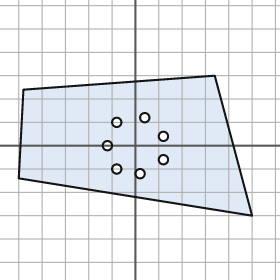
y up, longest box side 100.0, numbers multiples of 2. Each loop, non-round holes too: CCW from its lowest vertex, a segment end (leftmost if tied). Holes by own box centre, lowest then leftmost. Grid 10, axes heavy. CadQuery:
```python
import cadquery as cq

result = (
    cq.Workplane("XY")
    .moveTo(50.0, -30.0)
    .lineTo(34.0, 30.0)
    .lineTo(-48.0, 24.0)
    .lineTo(-50.0, -14.0)
    .close()
    .moveTo(2.0, -12.0)
    .circle(2.0)
    .moveTo(-8.0, -10.0)
    .circle(2.0)
    .moveTo(12.0, -6.0)
    .circle(2.0)
    .moveTo(-12.0, 0.0)
    .circle(2.0)
    .moveTo(12.0, 4.0)
    .circle(2.0)
    .moveTo(-8.0, 10.0)
    .circle(2.0)
    .moveTo(4.0, 12.0)
    .circle(2.0)
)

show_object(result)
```